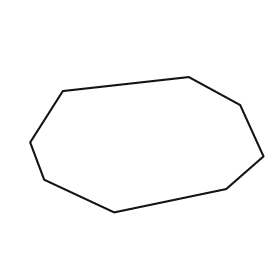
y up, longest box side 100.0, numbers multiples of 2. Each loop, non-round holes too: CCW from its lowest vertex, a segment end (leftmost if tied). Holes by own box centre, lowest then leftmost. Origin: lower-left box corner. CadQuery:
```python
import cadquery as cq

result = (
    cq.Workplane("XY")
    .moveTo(36.0, 0.0)
    .lineTo(84.0, 10.0)
    .lineTo(100.0, 24.0)
    .lineTo(90.0, 46.0)
    .lineTo(68.0, 58.0)
    .lineTo(14.0, 52.0)
    .lineTo(0.0, 30.0)
    .lineTo(6.0, 14.0)
    .close()
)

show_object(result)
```